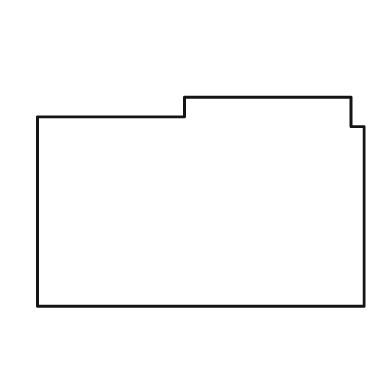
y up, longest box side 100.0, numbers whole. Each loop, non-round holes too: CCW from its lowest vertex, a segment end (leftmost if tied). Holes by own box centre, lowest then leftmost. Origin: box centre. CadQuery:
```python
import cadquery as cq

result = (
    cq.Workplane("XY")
    .moveTo(-50.0, -32.0)
    .lineTo(50.0, -32.0)
    .lineTo(50.0, 23.0)
    .lineTo(46.0, 23.0)
    .lineTo(46.0, 32.0)
    .lineTo(-5.0, 32.0)
    .lineTo(-5.0, 26.0)
    .lineTo(-50.0, 26.0)
    .close()
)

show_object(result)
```